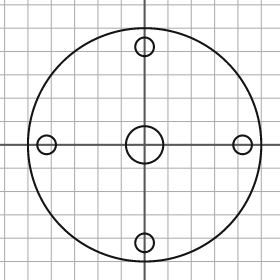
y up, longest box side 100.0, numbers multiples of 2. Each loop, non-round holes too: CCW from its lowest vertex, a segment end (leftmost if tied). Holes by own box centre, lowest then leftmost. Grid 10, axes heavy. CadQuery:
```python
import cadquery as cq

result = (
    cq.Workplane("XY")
    .moveTo(0.0, 0.0)
    .circle(50.0)
    .moveTo(0.0, -42.0)
    .circle(4.0)
    .moveTo(-42.0, 0.0)
    .circle(4.0)
    .moveTo(0.0, 0.0)
    .circle(8.0)
    .moveTo(42.0, 0.0)
    .circle(4.0)
    .moveTo(0.0, 42.0)
    .circle(4.0)
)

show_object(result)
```